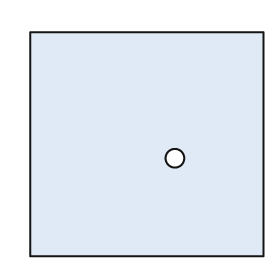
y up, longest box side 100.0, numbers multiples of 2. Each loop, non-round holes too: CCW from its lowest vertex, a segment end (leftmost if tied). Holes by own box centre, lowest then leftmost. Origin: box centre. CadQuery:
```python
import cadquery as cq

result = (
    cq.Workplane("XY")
    .moveTo(-50.0, -48.0)
    .lineTo(50.0, -48.0)
    .lineTo(50.0, 48.0)
    .lineTo(-50.0, 48.0)
    .close()
    .moveTo(12.0, -6.0)
    .circle(4.0)
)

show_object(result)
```